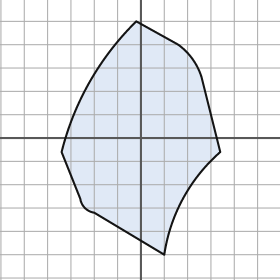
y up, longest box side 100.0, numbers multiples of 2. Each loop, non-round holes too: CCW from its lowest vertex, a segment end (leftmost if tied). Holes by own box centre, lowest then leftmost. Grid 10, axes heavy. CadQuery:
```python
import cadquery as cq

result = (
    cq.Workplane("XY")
    .moveTo(10.0, -50.0)
    .threePointArc((18.0, -26.0), (34.0, -6.0))
    .lineTo(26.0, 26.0)
    .threePointArc((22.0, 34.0), (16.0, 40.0))
    .lineTo(-2.0, 50.0)
    .threePointArc((-22.0, 24.0), (-34.0, -6.0))
    .lineTo(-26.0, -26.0)
    .threePointArc((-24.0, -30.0), (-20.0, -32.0))
    .close()
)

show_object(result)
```